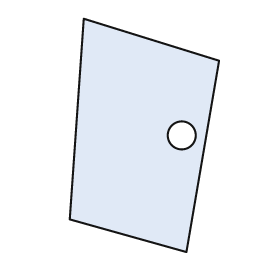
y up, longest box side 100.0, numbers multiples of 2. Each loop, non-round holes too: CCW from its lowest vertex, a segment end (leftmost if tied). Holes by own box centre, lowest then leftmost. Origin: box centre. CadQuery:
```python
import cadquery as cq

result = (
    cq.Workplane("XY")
    .moveTo(18.0, -50.0)
    .lineTo(32.0, 32.0)
    .lineTo(-26.0, 50.0)
    .lineTo(-32.0, -36.0)
    .close()
    .moveTo(16.0, 0.0)
    .circle(6.0)
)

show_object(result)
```